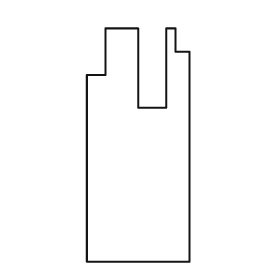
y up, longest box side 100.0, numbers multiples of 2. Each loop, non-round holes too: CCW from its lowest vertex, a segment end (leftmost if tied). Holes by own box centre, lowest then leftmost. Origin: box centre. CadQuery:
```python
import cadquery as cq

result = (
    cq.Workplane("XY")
    .moveTo(-22.0, -50.0)
    .lineTo(22.0, -50.0)
    .lineTo(22.0, 40.0)
    .lineTo(16.0, 40.0)
    .lineTo(16.0, 50.0)
    .lineTo(12.0, 50.0)
    .lineTo(12.0, 16.0)
    .lineTo(0.0, 16.0)
    .lineTo(0.0, 50.0)
    .lineTo(-14.0, 50.0)
    .lineTo(-14.0, 30.0)
    .lineTo(-22.0, 30.0)
    .close()
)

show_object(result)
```